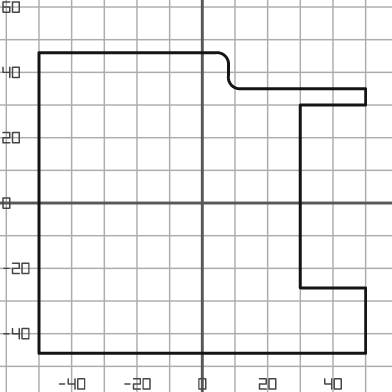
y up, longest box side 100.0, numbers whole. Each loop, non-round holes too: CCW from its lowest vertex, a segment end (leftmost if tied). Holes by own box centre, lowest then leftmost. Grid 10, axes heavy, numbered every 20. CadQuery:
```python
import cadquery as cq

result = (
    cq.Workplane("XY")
    .moveTo(-50.0, -46.0)
    .lineTo(50.0, -46.0)
    .lineTo(50.0, -26.0)
    .lineTo(30.0, -26.0)
    .lineTo(30.0, 30.0)
    .lineTo(50.0, 30.0)
    .lineTo(50.0, 35.0)
    .lineTo(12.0, 35.0)
    .threePointArc((9.0, 36.0), (8.0, 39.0))
    .lineTo(8.0, 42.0)
    .threePointArc((7.0, 45.0), (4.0, 46.0))
    .lineTo(-50.0, 46.0)
    .close()
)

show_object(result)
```